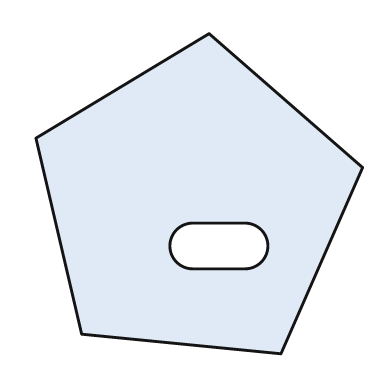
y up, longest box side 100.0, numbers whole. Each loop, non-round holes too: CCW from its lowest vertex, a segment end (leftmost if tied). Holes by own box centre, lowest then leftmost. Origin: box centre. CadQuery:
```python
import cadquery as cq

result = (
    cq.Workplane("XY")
    .moveTo(25.0, -49.0)
    .lineTo(50.0, 8.0)
    .lineTo(3.0, 49.0)
    .lineTo(-50.0, 17.0)
    .lineTo(-36.0, -43.0)
    .close()
    .moveTo(-2.0, -23.0)
    .lineTo(14.0, -23.0)
    .threePointArc((21.0, -16.0), (14.0, -9.0))
    .lineTo(-2.0, -9.0)
    .threePointArc((-9.0, -16.0), (-2.0, -23.0))
    .close()
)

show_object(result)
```